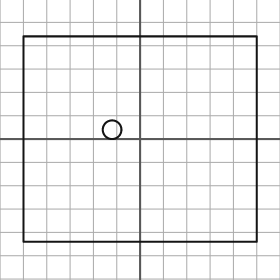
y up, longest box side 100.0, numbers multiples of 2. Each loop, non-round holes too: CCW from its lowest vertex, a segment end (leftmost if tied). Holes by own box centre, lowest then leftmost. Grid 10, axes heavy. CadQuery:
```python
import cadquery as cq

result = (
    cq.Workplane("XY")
    .moveTo(-50.0, -44.0)
    .lineTo(50.0, -44.0)
    .lineTo(50.0, 44.0)
    .lineTo(-50.0, 44.0)
    .close()
    .moveTo(-12.0, 4.0)
    .circle(4.0)
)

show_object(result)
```